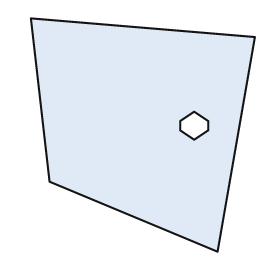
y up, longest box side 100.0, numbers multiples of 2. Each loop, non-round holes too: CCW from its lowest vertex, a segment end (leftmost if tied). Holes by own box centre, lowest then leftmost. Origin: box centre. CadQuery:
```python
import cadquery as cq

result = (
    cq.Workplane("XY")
    .moveTo(32.0, -50.0)
    .lineTo(48.0, 42.0)
    .lineTo(-48.0, 50.0)
    .lineTo(-40.0, -20.0)
    .close()
    .moveTo(22.0, -2.0)
    .lineTo(28.0, 2.0)
    .lineTo(28.0, 6.0)
    .lineTo(22.0, 10.0)
    .lineTo(16.0, 6.0)
    .lineTo(16.0, 2.0)
    .close()
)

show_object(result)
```